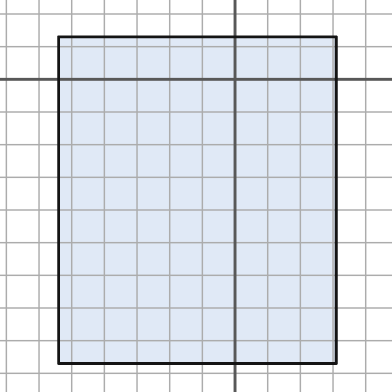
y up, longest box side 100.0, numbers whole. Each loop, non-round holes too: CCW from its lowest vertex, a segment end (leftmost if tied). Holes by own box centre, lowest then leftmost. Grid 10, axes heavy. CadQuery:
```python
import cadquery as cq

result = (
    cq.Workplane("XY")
    .moveTo(-54.0, -87.0)
    .lineTo(31.0, -87.0)
    .lineTo(31.0, 13.0)
    .lineTo(-54.0, 13.0)
    .close()
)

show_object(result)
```